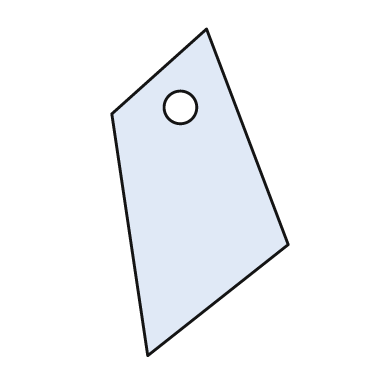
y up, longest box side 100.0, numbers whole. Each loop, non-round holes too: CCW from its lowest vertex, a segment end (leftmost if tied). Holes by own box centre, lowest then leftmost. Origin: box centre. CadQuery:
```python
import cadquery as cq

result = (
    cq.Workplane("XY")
    .moveTo(-16.0, -50.0)
    .lineTo(27.0, -16.0)
    .lineTo(2.0, 50.0)
    .lineTo(-27.0, 24.0)
    .close()
    .moveTo(-6.0, 26.0)
    .circle(5.0)
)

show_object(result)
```